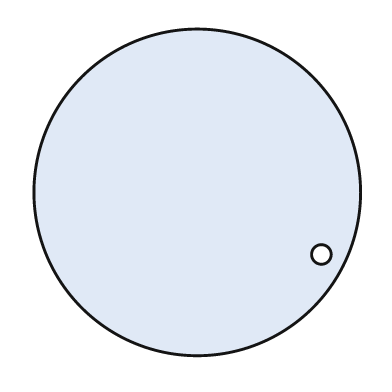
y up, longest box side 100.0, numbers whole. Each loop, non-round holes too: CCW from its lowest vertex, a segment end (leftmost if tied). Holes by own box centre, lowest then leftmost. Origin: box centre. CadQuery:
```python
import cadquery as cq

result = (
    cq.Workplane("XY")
    .moveTo(0.0, 0.0)
    .circle(50.0)
    .moveTo(38.0, -19.0)
    .circle(3.0)
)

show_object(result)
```